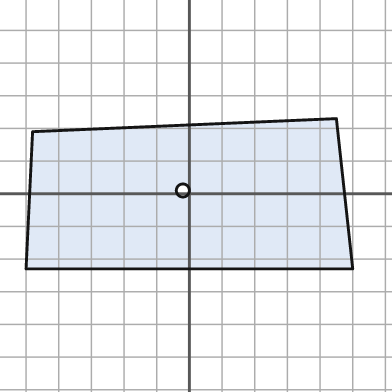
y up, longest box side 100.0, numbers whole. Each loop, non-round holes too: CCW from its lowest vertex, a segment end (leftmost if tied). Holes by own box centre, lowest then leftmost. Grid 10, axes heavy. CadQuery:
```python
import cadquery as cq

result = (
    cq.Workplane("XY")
    .moveTo(-50.0, -23.0)
    .lineTo(50.0, -23.0)
    .lineTo(45.0, 23.0)
    .lineTo(-48.0, 19.0)
    .close()
    .moveTo(-2.0, 1.0)
    .circle(2.0)
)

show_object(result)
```